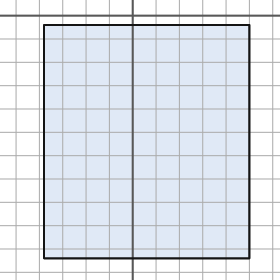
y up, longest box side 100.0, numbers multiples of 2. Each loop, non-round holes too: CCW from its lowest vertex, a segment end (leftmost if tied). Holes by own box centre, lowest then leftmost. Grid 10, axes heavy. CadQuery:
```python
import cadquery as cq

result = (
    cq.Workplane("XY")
    .moveTo(-38.0, -104.0)
    .lineTo(50.0, -104.0)
    .lineTo(50.0, -4.0)
    .lineTo(-38.0, -4.0)
    .close()
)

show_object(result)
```